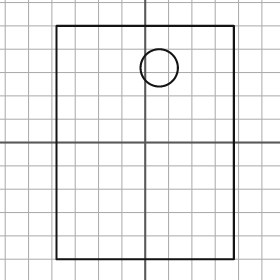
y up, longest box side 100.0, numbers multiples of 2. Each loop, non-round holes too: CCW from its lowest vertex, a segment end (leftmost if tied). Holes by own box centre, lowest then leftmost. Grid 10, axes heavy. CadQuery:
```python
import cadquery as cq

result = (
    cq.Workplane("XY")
    .moveTo(-38.0, -50.0)
    .lineTo(38.0, -50.0)
    .lineTo(38.0, 50.0)
    .lineTo(-38.0, 50.0)
    .close()
    .moveTo(6.0, 32.0)
    .circle(8.0)
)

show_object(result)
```